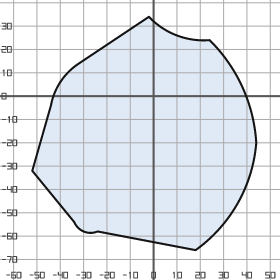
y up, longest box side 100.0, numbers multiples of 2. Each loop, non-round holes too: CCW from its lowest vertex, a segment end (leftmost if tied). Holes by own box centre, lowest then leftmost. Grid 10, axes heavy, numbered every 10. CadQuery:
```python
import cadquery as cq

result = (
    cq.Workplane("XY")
    .moveTo(18.0, -66.0)
    .threePointArc((36.0, -46.0), (44.0, -20.0))
    .threePointArc((38.0, 4.0), (24.0, 24.0))
    .threePointArc((10.0, 26.0), (-2.0, 34.0))
    .lineTo(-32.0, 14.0)
    .threePointArc((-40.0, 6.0), (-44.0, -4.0))
    .lineTo(-52.0, -32.0)
    .lineTo(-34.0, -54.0)
    .threePointArc((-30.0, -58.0), (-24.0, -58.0))
    .close()
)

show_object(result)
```